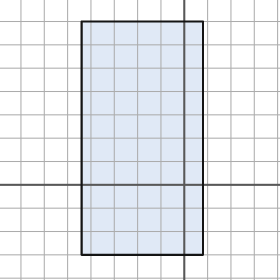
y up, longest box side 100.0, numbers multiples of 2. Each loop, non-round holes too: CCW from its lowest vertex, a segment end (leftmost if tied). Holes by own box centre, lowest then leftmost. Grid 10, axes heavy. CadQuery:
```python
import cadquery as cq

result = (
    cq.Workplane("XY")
    .moveTo(-44.0, -30.0)
    .lineTo(8.0, -30.0)
    .lineTo(8.0, 70.0)
    .lineTo(-44.0, 70.0)
    .close()
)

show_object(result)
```